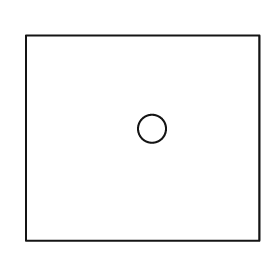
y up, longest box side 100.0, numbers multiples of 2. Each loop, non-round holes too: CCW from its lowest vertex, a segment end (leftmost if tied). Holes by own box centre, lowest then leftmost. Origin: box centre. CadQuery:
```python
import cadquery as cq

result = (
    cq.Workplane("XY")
    .moveTo(-50.0, -44.0)
    .lineTo(50.0, -44.0)
    .lineTo(50.0, 44.0)
    .lineTo(-50.0, 44.0)
    .close()
    .moveTo(4.0, 4.0)
    .circle(6.0)
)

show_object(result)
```